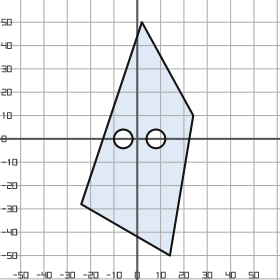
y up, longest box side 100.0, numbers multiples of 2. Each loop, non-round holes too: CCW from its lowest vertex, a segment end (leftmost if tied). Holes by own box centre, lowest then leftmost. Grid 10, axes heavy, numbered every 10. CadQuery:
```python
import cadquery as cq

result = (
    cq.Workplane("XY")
    .moveTo(14.0, -50.0)
    .lineTo(24.0, 10.0)
    .lineTo(2.0, 50.0)
    .lineTo(-24.0, -28.0)
    .close()
    .moveTo(-6.0, 0.0)
    .circle(4.0)
    .moveTo(8.0, 0.0)
    .circle(4.0)
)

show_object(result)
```